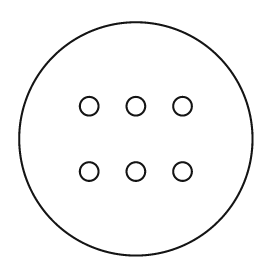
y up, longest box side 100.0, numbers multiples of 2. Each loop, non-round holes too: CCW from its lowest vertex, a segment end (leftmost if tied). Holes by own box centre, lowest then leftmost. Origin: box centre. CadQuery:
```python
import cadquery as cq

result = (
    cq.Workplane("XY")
    .moveTo(0.0, 0.0)
    .circle(50.0)
    .moveTo(-20.0, -14.0)
    .circle(4.0)
    .moveTo(0.0, -14.0)
    .circle(4.0)
    .moveTo(20.0, -14.0)
    .circle(4.0)
    .moveTo(-20.0, 14.0)
    .circle(4.0)
    .moveTo(0.0, 14.0)
    .circle(4.0)
    .moveTo(20.0, 14.0)
    .circle(4.0)
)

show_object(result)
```